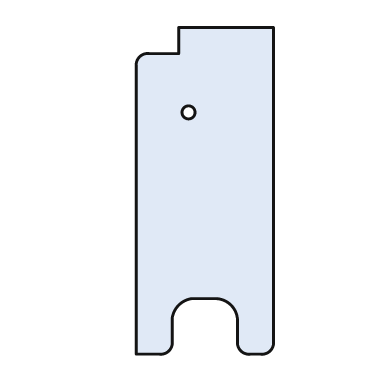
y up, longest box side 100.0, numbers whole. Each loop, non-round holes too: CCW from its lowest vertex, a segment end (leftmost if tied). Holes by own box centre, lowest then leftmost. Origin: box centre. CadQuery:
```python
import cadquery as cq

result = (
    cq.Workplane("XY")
    .moveTo(-21.0, -50.0)
    .lineTo(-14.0, -50.0)
    .threePointArc((-11.0, -49.0), (-10.0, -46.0))
    .lineTo(-10.0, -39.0)
    .threePointArc((-8.0, -35.0), (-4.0, -33.0))
    .lineTo(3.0, -33.0)
    .threePointArc((8.0, -35.0), (10.0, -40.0))
    .lineTo(10.0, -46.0)
    .threePointArc((11.0, -49.0), (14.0, -50.0))
    .lineTo(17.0, -50.0)
    .threePointArc((20.0, -49.0), (21.0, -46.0))
    .lineTo(21.0, 50.0)
    .lineTo(-8.0, 50.0)
    .lineTo(-8.0, 42.0)
    .lineTo(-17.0, 42.0)
    .threePointArc((-20.0, 41.0), (-21.0, 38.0))
    .close()
    .moveTo(-5.0, 24.0)
    .circle(2.0)
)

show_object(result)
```